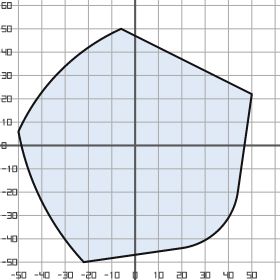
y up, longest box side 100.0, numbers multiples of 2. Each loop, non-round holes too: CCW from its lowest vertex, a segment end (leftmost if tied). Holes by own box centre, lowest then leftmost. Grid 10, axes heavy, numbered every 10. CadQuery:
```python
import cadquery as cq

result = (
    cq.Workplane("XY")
    .moveTo(-22.0, -50.0)
    .lineTo(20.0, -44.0)
    .threePointArc((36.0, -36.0), (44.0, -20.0))
    .lineTo(50.0, 22.0)
    .lineTo(-6.0, 50.0)
    .threePointArc((-32.0, 32.0), (-50.0, 6.0))
    .threePointArc((-40.0, -24.0), (-22.0, -50.0))
    .close()
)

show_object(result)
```